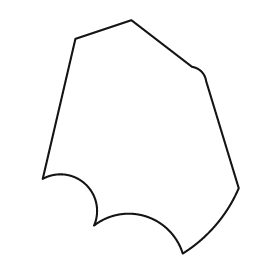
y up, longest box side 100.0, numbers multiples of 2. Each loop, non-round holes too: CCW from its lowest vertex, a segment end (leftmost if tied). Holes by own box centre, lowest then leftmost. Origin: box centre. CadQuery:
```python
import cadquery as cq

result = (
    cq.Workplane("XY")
    .moveTo(18.0, -50.0)
    .threePointArc((32.0, -38.0), (42.0, -22.0))
    .lineTo(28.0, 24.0)
    .threePointArc((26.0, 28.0), (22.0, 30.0))
    .lineTo(-4.0, 50.0)
    .lineTo(-28.0, 42.0)
    .lineTo(-42.0, -18.0)
    .threePointArc((-24.0, -20.0), (-20.0, -38.0))
    .threePointArc((2.0, -34.0), (18.0, -50.0))
    .close()
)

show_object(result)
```